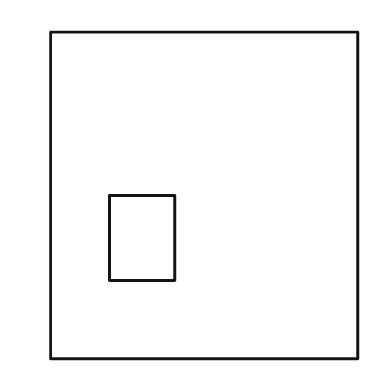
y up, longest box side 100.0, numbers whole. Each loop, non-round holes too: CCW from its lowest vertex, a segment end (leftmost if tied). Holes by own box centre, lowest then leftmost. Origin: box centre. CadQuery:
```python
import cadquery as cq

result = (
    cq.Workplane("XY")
    .moveTo(-47.0, -50.0)
    .lineTo(47.0, -50.0)
    .lineTo(47.0, 50.0)
    .lineTo(-47.0, 50.0)
    .close()
    .moveTo(-29.0, -26.0)
    .lineTo(-9.0, -26.0)
    .lineTo(-9.0, 0.0)
    .lineTo(-29.0, 0.0)
    .close()
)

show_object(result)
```